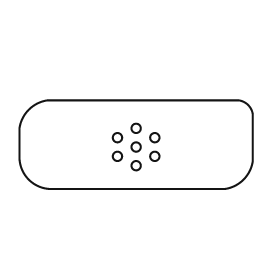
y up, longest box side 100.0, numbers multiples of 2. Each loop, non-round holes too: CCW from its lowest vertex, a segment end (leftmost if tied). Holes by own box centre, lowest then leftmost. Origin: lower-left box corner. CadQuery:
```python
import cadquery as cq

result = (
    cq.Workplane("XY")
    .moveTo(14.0, 0.0)
    .lineTo(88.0, 0.0)
    .threePointArc((96.0, 4.0), (100.0, 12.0))
    .lineTo(100.0, 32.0)
    .threePointArc((98.0, 36.0), (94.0, 38.0))
    .lineTo(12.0, 38.0)
    .threePointArc((4.0, 34.0), (0.0, 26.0))
    .lineTo(0.0, 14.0)
    .threePointArc((4.0, 4.0), (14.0, 0.0))
    .close()
    .moveTo(50.0, 10.0)
    .circle(2.0)
    .moveTo(42.0, 14.0)
    .circle(2.0)
    .moveTo(58.0, 14.0)
    .circle(2.0)
    .moveTo(50.0, 18.0)
    .circle(2.0)
    .moveTo(42.0, 22.0)
    .circle(2.0)
    .moveTo(58.0, 22.0)
    .circle(2.0)
    .moveTo(50.0, 26.0)
    .circle(2.0)
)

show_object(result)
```